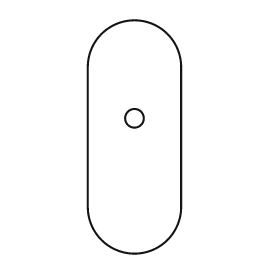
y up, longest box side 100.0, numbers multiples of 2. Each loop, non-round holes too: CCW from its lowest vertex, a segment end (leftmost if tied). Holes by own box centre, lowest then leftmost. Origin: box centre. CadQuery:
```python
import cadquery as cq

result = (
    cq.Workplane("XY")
    .moveTo(-20.0, -30.0)
    .threePointArc((0.0, -50.0), (20.0, -30.0))
    .lineTo(20.0, 30.0)
    .threePointArc((0.0, 50.0), (-20.0, 30.0))
    .close()
    .moveTo(0.0, 8.0)
    .circle(4.0)
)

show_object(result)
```